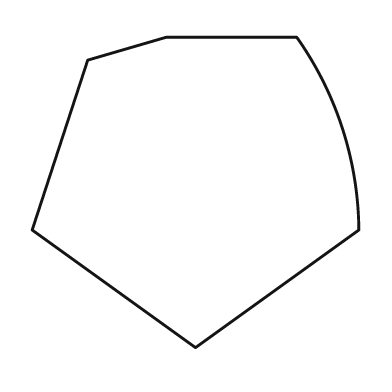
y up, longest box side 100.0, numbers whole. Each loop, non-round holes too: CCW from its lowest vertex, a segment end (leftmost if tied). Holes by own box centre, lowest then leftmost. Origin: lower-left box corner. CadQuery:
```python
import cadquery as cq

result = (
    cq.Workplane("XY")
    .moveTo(50.0, 0.0)
    .lineTo(100.0, 36.0)
    .threePointArc((95.0, 67.0), (81.0, 95.0))
    .lineTo(41.0, 95.0)
    .lineTo(17.0, 88.0)
    .lineTo(0.0, 36.0)
    .close()
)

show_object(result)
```